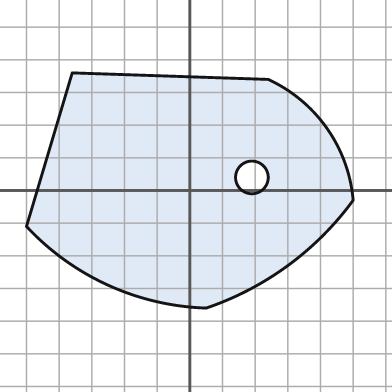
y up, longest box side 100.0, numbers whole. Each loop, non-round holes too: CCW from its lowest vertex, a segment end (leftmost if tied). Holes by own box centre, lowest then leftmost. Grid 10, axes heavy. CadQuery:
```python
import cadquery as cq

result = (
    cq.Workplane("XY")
    .moveTo(5.0, -36.0)
    .threePointArc((30.0, -23.0), (50.0, -3.0))
    .threePointArc((42.0, 19.0), (24.0, 34.0))
    .lineTo(-36.0, 36.0)
    .lineTo(-50.0, -11.0)
    .threePointArc((-25.0, -29.0), (5.0, -36.0))
    .close()
    .moveTo(19.0, 4.0)
    .circle(5.0)
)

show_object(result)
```